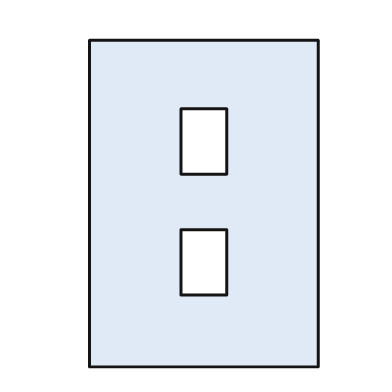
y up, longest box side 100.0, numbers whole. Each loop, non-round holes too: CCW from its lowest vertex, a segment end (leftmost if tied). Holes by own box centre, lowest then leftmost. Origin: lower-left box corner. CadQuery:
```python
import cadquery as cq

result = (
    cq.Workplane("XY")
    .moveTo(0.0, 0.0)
    .lineTo(70.0, 0.0)
    .lineTo(70.0, 100.0)
    .lineTo(0.0, 100.0)
    .close()
    .moveTo(28.0, 22.0)
    .lineTo(42.0, 22.0)
    .lineTo(42.0, 42.0)
    .lineTo(28.0, 42.0)
    .close()
    .moveTo(28.0, 59.0)
    .lineTo(42.0, 59.0)
    .lineTo(42.0, 79.0)
    .lineTo(28.0, 79.0)
    .close()
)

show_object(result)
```